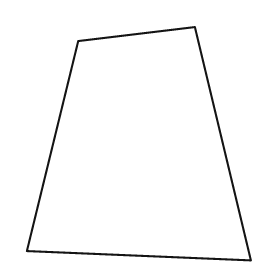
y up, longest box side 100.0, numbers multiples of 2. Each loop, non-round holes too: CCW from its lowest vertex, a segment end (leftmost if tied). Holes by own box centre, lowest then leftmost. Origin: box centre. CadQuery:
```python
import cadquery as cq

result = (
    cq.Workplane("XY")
    .moveTo(48.0, -50.0)
    .lineTo(24.0, 50.0)
    .lineTo(-26.0, 44.0)
    .lineTo(-48.0, -46.0)
    .close()
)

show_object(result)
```